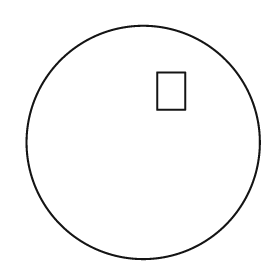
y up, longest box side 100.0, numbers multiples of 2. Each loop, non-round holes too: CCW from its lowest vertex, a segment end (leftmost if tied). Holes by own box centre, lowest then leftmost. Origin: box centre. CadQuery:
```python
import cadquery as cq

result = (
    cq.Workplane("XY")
    .moveTo(0.0, 0.0)
    .circle(50.0)
    .moveTo(6.0, 14.0)
    .lineTo(18.0, 14.0)
    .lineTo(18.0, 30.0)
    .lineTo(6.0, 30.0)
    .close()
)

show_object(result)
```